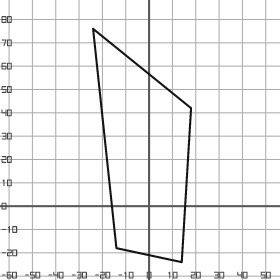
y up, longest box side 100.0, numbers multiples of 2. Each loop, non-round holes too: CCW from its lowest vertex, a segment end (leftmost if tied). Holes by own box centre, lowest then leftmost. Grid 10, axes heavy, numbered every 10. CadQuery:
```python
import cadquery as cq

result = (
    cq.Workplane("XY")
    .moveTo(14.0, -24.0)
    .lineTo(18.0, 42.0)
    .lineTo(-24.0, 76.0)
    .lineTo(-14.0, -18.0)
    .close()
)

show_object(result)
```